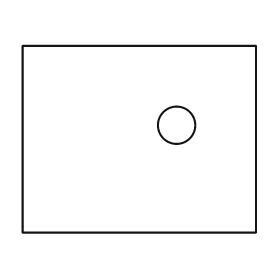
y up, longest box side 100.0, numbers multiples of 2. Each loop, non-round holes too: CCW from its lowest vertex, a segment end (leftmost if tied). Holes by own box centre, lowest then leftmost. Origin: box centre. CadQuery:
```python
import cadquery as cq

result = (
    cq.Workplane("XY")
    .moveTo(-50.0, -40.0)
    .lineTo(50.0, -40.0)
    .lineTo(50.0, 40.0)
    .lineTo(-50.0, 40.0)
    .close()
    .moveTo(16.0, 6.0)
    .circle(8.0)
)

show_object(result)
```